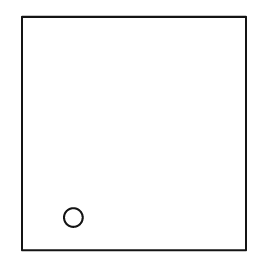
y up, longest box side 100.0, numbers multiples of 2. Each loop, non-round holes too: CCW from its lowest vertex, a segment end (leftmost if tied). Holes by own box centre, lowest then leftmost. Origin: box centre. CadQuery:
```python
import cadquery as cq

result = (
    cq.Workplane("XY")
    .moveTo(-48.0, -50.0)
    .lineTo(48.0, -50.0)
    .lineTo(48.0, 50.0)
    .lineTo(-48.0, 50.0)
    .close()
    .moveTo(-26.0, -36.0)
    .circle(4.0)
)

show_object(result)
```